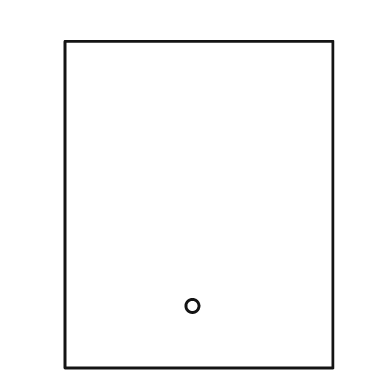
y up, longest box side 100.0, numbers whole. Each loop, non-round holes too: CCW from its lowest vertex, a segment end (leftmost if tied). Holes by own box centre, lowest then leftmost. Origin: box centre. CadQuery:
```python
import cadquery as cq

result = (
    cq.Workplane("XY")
    .moveTo(-41.0, -50.0)
    .lineTo(41.0, -50.0)
    .lineTo(41.0, 50.0)
    .lineTo(-41.0, 50.0)
    .close()
    .moveTo(-2.0, -31.0)
    .circle(2.0)
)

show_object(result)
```